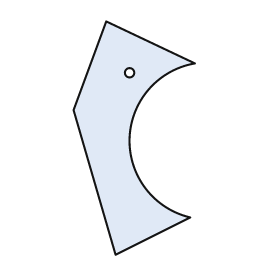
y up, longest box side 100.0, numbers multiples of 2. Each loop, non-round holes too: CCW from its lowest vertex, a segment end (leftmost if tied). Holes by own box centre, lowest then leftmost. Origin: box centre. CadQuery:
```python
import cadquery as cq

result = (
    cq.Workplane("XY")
    .moveTo(-8.0, -50.0)
    .lineTo(24.0, -34.0)
    .threePointArc((-2.0, 0.0), (26.0, 32.0))
    .lineTo(-12.0, 50.0)
    .lineTo(-26.0, 12.0)
    .close()
    .moveTo(-2.0, 28.0)
    .circle(2.0)
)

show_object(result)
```